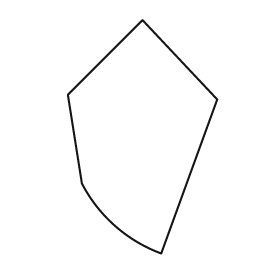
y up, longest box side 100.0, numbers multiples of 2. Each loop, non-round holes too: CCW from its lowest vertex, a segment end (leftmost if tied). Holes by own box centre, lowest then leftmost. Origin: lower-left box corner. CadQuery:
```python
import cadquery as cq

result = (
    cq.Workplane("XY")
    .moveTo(40.0, 0.0)
    .lineTo(64.0, 66.0)
    .lineTo(32.0, 100.0)
    .lineTo(0.0, 68.0)
    .lineTo(6.0, 30.0)
    .threePointArc((20.0, 12.0), (40.0, 0.0))
    .close()
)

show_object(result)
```